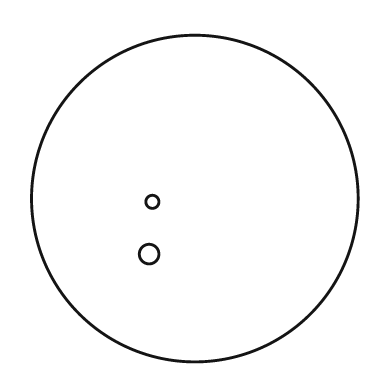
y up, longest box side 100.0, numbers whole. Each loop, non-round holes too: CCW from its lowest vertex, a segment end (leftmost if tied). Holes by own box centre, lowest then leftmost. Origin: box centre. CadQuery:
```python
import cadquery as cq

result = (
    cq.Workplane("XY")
    .moveTo(0.0, 0.0)
    .circle(50.0)
    .moveTo(-14.0, -17.0)
    .circle(3.0)
    .moveTo(-13.0, -1.0)
    .circle(2.0)
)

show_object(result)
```